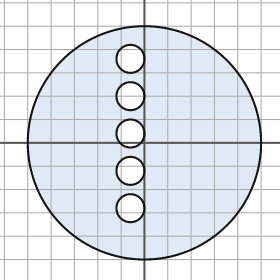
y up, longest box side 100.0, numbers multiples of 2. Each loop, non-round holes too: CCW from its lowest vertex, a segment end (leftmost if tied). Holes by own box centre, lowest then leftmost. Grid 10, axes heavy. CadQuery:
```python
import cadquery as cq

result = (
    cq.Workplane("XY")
    .moveTo(0.0, 0.0)
    .circle(50.0)
    .moveTo(-6.0, -28.0)
    .circle(6.0)
    .moveTo(-6.0, -12.0)
    .circle(6.0)
    .moveTo(-6.0, 4.0)
    .circle(6.0)
    .moveTo(-6.0, 20.0)
    .circle(6.0)
    .moveTo(-6.0, 36.0)
    .circle(6.0)
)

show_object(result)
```